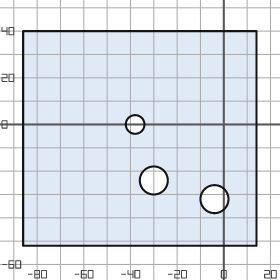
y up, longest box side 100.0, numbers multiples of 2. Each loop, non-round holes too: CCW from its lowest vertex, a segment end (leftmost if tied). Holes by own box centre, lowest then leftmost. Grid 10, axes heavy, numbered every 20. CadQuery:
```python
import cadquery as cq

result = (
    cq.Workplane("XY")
    .moveTo(-86.0, -52.0)
    .lineTo(14.0, -52.0)
    .lineTo(14.0, 40.0)
    .lineTo(-86.0, 40.0)
    .close()
    .moveTo(-4.0, -32.0)
    .circle(6.0)
    .moveTo(-30.0, -24.0)
    .circle(6.0)
    .moveTo(-38.0, 0.0)
    .circle(4.0)
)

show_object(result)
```